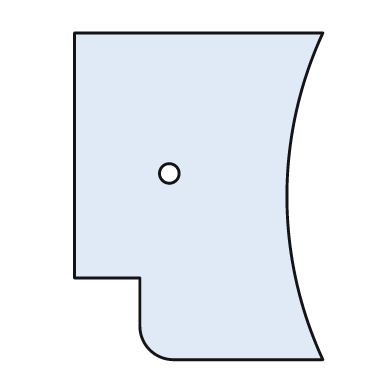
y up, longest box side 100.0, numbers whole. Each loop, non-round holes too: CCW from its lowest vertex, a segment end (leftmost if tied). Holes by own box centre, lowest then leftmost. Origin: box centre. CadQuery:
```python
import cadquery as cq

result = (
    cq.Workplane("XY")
    .moveTo(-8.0, -50.0)
    .lineTo(38.0, -50.0)
    .threePointArc((27.0, 0.0), (38.0, 50.0))
    .lineTo(-38.0, 50.0)
    .lineTo(-38.0, -25.0)
    .lineTo(-18.0, -25.0)
    .lineTo(-18.0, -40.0)
    .threePointArc((-15.0, -47.0), (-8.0, -50.0))
    .close()
    .moveTo(-9.0, 7.0)
    .circle(3.0)
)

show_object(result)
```